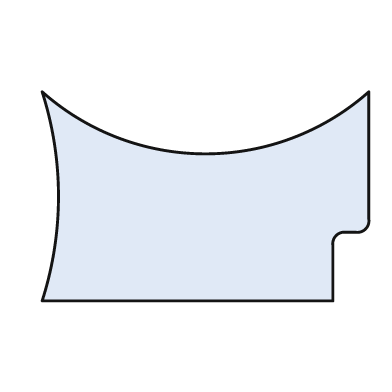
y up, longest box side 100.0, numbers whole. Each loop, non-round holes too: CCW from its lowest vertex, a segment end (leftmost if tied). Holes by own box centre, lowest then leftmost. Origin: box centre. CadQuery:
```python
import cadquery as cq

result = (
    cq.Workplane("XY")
    .moveTo(-50.0, -32.0)
    .lineTo(39.0, -32.0)
    .lineTo(39.0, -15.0)
    .threePointArc((40.0, -12.0), (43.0, -11.0))
    .lineTo(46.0, -11.0)
    .threePointArc((49.0, -10.0), (50.0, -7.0))
    .lineTo(50.0, 32.0)
    .threePointArc((0.0, 13.0), (-50.0, 32.0))
    .threePointArc((-45.0, 0.0), (-50.0, -32.0))
    .close()
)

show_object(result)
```